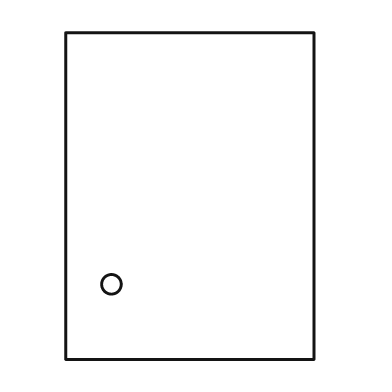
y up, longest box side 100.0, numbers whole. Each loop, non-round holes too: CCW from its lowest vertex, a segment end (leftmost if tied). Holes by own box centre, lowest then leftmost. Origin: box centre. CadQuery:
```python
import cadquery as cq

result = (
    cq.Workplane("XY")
    .moveTo(-38.0, -50.0)
    .lineTo(38.0, -50.0)
    .lineTo(38.0, 50.0)
    .lineTo(-38.0, 50.0)
    .close()
    .moveTo(-24.0, -27.0)
    .circle(3.0)
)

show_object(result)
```